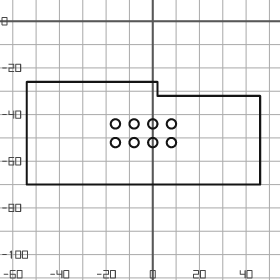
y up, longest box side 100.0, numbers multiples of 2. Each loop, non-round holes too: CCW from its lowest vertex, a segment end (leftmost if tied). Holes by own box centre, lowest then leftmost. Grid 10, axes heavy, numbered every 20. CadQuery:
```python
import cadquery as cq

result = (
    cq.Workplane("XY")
    .moveTo(-54.0, -70.0)
    .lineTo(46.0, -70.0)
    .lineTo(46.0, -32.0)
    .lineTo(2.0, -32.0)
    .lineTo(2.0, -26.0)
    .lineTo(-54.0, -26.0)
    .close()
    .moveTo(-16.0, -52.0)
    .circle(2.0)
    .moveTo(-8.0, -52.0)
    .circle(2.0)
    .moveTo(0.0, -52.0)
    .circle(2.0)
    .moveTo(8.0, -52.0)
    .circle(2.0)
    .moveTo(-16.0, -44.0)
    .circle(2.0)
    .moveTo(-8.0, -44.0)
    .circle(2.0)
    .moveTo(0.0, -44.0)
    .circle(2.0)
    .moveTo(8.0, -44.0)
    .circle(2.0)
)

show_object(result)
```